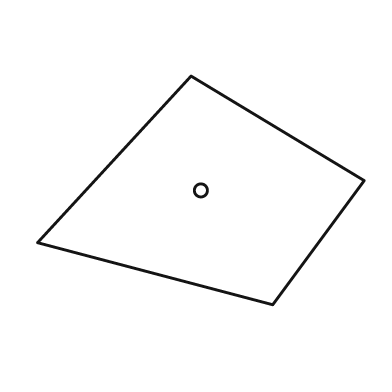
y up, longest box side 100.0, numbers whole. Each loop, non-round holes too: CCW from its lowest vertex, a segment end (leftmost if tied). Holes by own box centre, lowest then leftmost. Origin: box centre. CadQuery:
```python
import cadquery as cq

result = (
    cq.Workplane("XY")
    .moveTo(22.0, -35.0)
    .lineTo(50.0, 3.0)
    .lineTo(-3.0, 35.0)
    .lineTo(-50.0, -16.0)
    .close()
    .moveTo(0.0, 0.0)
    .circle(2.0)
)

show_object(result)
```